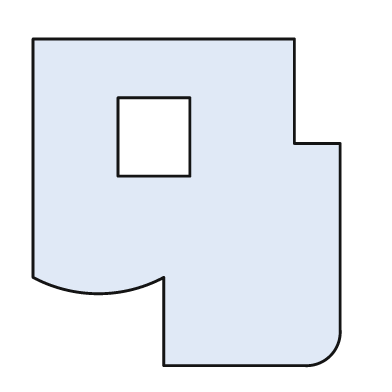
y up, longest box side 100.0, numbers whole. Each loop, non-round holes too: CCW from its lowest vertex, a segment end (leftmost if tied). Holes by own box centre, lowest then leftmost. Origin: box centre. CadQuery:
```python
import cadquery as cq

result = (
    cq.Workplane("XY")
    .moveTo(-7.0, -50.0)
    .lineTo(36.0, -50.0)
    .threePointArc((44.0, -47.0), (47.0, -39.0))
    .lineTo(47.0, 18.0)
    .lineTo(33.0, 18.0)
    .lineTo(33.0, 50.0)
    .lineTo(-47.0, 50.0)
    .lineTo(-47.0, -23.0)
    .threePointArc((-27.0, -28.0), (-7.0, -23.0))
    .close()
    .moveTo(-21.0, 8.0)
    .lineTo(1.0, 8.0)
    .lineTo(1.0, 32.0)
    .lineTo(-21.0, 32.0)
    .close()
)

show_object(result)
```